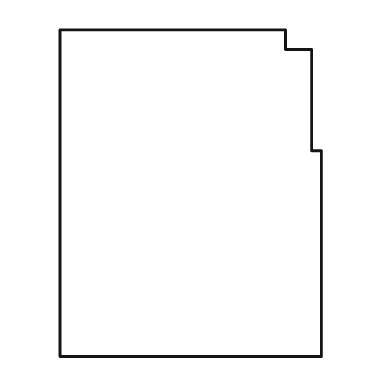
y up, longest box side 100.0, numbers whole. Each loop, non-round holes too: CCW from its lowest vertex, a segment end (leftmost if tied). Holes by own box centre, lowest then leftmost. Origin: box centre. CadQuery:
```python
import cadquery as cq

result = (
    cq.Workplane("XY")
    .moveTo(-40.0, -50.0)
    .lineTo(40.0, -50.0)
    .lineTo(40.0, 13.0)
    .lineTo(37.0, 13.0)
    .lineTo(37.0, 44.0)
    .lineTo(29.0, 44.0)
    .lineTo(29.0, 50.0)
    .lineTo(-40.0, 50.0)
    .close()
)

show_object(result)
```